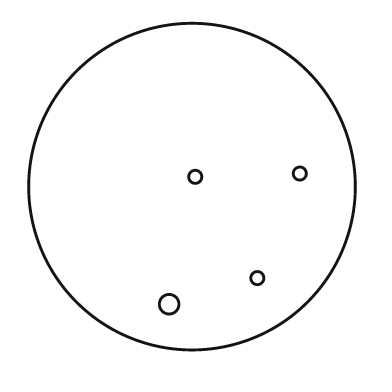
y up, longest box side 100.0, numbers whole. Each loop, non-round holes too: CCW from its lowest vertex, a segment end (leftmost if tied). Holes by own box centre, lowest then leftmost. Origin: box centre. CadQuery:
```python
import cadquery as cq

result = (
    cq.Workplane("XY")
    .moveTo(0.0, 0.0)
    .circle(50.0)
    .moveTo(-7.0, -36.0)
    .circle(3.0)
    .moveTo(20.0, -28.0)
    .circle(2.0)
    .moveTo(1.0, 3.0)
    .circle(2.0)
    .moveTo(33.0, 4.0)
    .circle(2.0)
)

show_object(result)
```